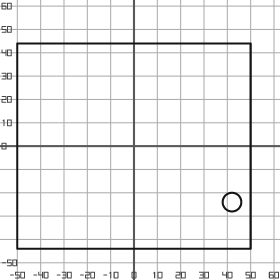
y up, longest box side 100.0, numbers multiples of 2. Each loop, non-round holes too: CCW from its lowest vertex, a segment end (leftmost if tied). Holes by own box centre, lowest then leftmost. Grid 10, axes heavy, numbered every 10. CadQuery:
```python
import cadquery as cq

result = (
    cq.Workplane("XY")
    .moveTo(-50.0, -44.0)
    .lineTo(50.0, -44.0)
    .lineTo(50.0, 44.0)
    .lineTo(-50.0, 44.0)
    .close()
    .moveTo(42.0, -24.0)
    .circle(4.0)
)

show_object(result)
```